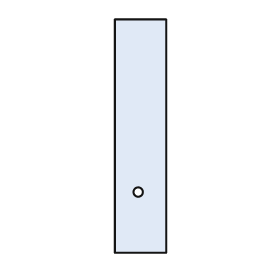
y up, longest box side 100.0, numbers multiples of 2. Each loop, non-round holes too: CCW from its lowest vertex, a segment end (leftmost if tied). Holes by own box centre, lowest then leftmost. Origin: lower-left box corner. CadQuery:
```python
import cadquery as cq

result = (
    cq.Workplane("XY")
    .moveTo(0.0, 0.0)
    .lineTo(22.0, 0.0)
    .lineTo(22.0, 100.0)
    .lineTo(0.0, 100.0)
    .close()
    .moveTo(10.0, 26.0)
    .circle(2.0)
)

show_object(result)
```